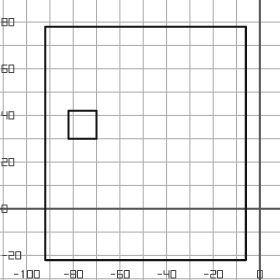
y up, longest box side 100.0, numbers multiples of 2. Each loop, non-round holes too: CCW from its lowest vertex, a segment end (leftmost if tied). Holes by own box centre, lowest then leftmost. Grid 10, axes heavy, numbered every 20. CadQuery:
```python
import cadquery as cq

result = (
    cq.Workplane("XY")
    .moveTo(-92.0, -22.0)
    .lineTo(-6.0, -22.0)
    .lineTo(-6.0, 78.0)
    .lineTo(-92.0, 78.0)
    .close()
    .moveTo(-82.0, 30.0)
    .lineTo(-70.0, 30.0)
    .lineTo(-70.0, 42.0)
    .lineTo(-82.0, 42.0)
    .close()
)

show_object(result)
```